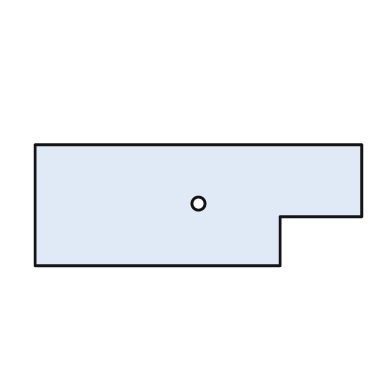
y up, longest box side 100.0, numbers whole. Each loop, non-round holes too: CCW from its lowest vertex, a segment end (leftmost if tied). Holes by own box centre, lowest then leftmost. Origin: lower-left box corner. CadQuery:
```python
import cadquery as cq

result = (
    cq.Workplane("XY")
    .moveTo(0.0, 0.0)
    .lineTo(75.0, 0.0)
    .lineTo(75.0, 15.0)
    .lineTo(100.0, 15.0)
    .lineTo(100.0, 37.0)
    .lineTo(0.0, 37.0)
    .close()
    .moveTo(50.0, 19.0)
    .circle(2.0)
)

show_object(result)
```